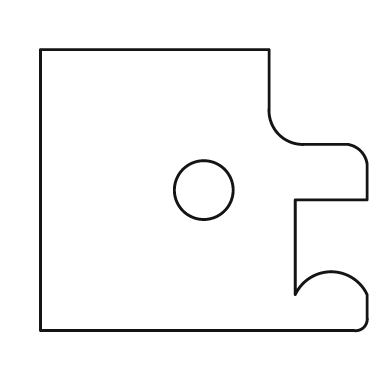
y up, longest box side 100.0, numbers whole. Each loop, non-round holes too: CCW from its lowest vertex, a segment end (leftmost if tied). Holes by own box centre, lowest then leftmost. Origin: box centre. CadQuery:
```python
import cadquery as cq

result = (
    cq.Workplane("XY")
    .moveTo(-50.0, -43.0)
    .lineTo(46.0, -43.0)
    .threePointArc((49.0, -42.0), (50.0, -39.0))
    .lineTo(50.0, -32.0)
    .threePointArc((39.0, -25.0), (28.0, -32.0))
    .lineTo(28.0, -3.0)
    .lineTo(50.0, -3.0)
    .lineTo(50.0, 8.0)
    .threePointArc((48.0, 12.0), (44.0, 14.0))
    .lineTo(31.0, 14.0)
    .threePointArc((23.0, 17.0), (20.0, 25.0))
    .lineTo(20.0, 43.0)
    .lineTo(-50.0, 43.0)
    .close()
    .moveTo(0.0, 0.0)
    .circle(9.0)
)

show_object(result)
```